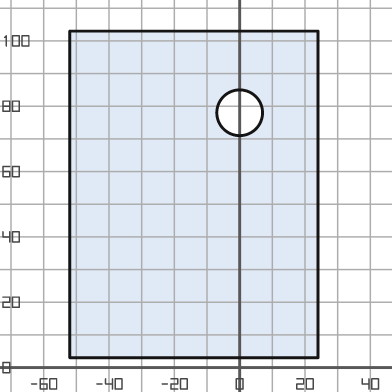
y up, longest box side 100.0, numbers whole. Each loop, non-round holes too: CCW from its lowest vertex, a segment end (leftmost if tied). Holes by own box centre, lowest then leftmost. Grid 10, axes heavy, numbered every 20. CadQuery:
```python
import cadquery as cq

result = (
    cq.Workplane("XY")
    .moveTo(-52.0, 3.0)
    .lineTo(24.0, 3.0)
    .lineTo(24.0, 103.0)
    .lineTo(-52.0, 103.0)
    .close()
    .moveTo(0.0, 78.0)
    .circle(7.0)
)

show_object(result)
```